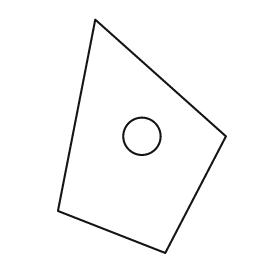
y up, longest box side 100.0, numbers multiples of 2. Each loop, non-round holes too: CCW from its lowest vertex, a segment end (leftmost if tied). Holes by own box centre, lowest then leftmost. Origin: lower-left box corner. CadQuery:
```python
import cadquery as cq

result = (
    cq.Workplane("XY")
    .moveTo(46.0, 0.0)
    .lineTo(72.0, 50.0)
    .lineTo(16.0, 100.0)
    .lineTo(0.0, 18.0)
    .close()
    .moveTo(36.0, 50.0)
    .circle(8.0)
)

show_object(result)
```